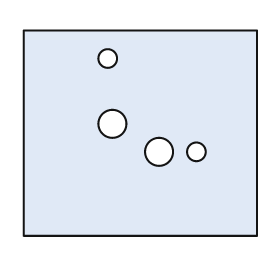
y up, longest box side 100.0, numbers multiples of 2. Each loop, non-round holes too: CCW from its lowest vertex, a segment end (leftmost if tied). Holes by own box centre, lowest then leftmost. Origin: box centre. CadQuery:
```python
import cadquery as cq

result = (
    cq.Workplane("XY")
    .moveTo(-50.0, -44.0)
    .lineTo(50.0, -44.0)
    .lineTo(50.0, 44.0)
    .lineTo(-50.0, 44.0)
    .close()
    .moveTo(8.0, -8.0)
    .circle(6.0)
    .moveTo(24.0, -8.0)
    .circle(4.0)
    .moveTo(-12.0, 4.0)
    .circle(6.0)
    .moveTo(-14.0, 32.0)
    .circle(4.0)
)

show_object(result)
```